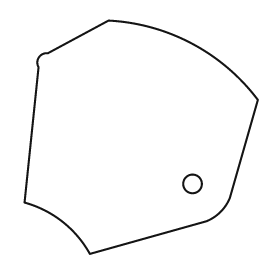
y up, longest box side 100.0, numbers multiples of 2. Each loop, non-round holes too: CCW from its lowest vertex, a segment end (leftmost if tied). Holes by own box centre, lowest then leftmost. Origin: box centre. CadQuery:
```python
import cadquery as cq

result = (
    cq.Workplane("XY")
    .moveTo(-22.0, -50.0)
    .lineTo(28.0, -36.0)
    .threePointArc((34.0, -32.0), (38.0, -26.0))
    .lineTo(50.0, 16.0)
    .threePointArc((22.0, 40.0), (-14.0, 50.0))
    .lineTo(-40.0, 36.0)
    .threePointArc((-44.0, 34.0), (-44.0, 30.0))
    .lineTo(-50.0, -28.0)
    .threePointArc((-34.0, -36.0), (-22.0, -50.0))
    .close()
    .moveTo(22.0, -20.0)
    .circle(4.0)
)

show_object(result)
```